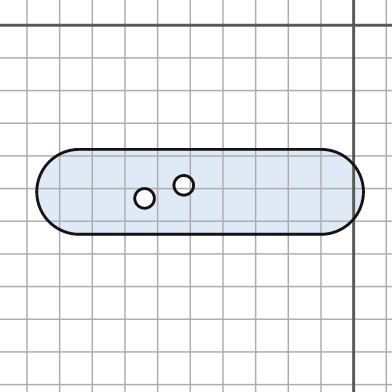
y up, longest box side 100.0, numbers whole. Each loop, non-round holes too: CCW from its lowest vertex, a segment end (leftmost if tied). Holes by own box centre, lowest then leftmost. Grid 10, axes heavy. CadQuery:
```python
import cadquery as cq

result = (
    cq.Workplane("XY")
    .moveTo(-84.0, -64.0)
    .lineTo(-10.0, -64.0)
    .threePointArc((3.0, -51.0), (-10.0, -38.0))
    .lineTo(-84.0, -38.0)
    .threePointArc((-97.0, -51.0), (-84.0, -64.0))
    .close()
    .moveTo(-64.0, -53.0)
    .circle(3.0)
    .moveTo(-52.0, -49.0)
    .circle(3.0)
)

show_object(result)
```